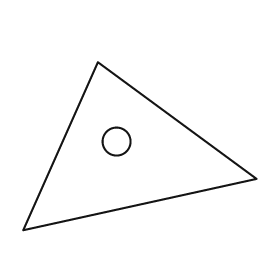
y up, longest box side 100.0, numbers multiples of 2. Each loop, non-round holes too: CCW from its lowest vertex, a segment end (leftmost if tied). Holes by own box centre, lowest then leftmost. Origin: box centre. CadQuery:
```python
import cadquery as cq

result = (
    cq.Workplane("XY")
    .moveTo(-50.0, -36.0)
    .lineTo(50.0, -14.0)
    .lineTo(-18.0, 36.0)
    .close()
    .moveTo(-10.0, 2.0)
    .circle(6.0)
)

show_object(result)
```